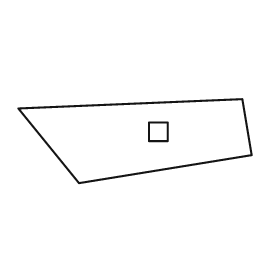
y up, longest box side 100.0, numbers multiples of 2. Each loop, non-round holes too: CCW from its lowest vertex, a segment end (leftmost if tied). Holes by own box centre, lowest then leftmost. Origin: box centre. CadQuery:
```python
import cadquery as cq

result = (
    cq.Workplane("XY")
    .moveTo(-24.0, -18.0)
    .lineTo(50.0, -6.0)
    .lineTo(46.0, 18.0)
    .lineTo(-50.0, 14.0)
    .close()
    .moveTo(6.0, 0.0)
    .lineTo(14.0, 0.0)
    .lineTo(14.0, 8.0)
    .lineTo(6.0, 8.0)
    .close()
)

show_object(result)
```